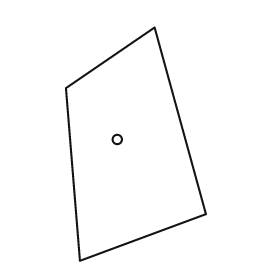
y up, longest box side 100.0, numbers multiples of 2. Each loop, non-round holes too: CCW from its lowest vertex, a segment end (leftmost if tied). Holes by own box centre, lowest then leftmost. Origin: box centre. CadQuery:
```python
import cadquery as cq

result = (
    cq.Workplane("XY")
    .moveTo(-24.0, -50.0)
    .lineTo(30.0, -30.0)
    .lineTo(8.0, 50.0)
    .lineTo(-30.0, 24.0)
    .close()
    .moveTo(-8.0, 2.0)
    .circle(2.0)
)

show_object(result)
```